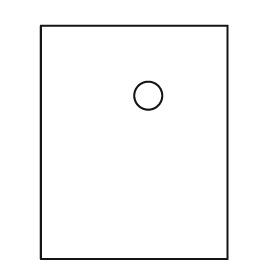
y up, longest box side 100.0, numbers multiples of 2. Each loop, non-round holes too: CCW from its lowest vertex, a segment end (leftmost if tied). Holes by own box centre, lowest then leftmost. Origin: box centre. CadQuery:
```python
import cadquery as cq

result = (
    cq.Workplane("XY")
    .moveTo(-40.0, -50.0)
    .lineTo(40.0, -50.0)
    .lineTo(40.0, 50.0)
    .lineTo(-40.0, 50.0)
    .close()
    .moveTo(6.0, 20.0)
    .circle(6.0)
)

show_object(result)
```